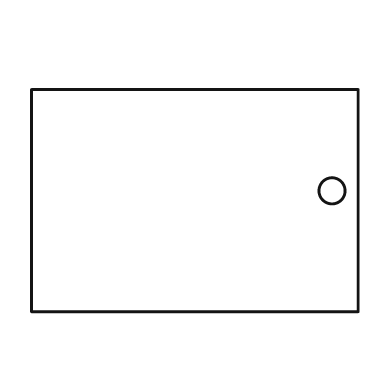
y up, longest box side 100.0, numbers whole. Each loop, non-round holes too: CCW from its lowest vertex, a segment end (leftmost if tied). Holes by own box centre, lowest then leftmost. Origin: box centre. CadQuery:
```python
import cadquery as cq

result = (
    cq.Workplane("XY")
    .moveTo(-50.0, -34.0)
    .lineTo(50.0, -34.0)
    .lineTo(50.0, 34.0)
    .lineTo(-50.0, 34.0)
    .close()
    .moveTo(42.0, 3.0)
    .circle(4.0)
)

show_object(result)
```